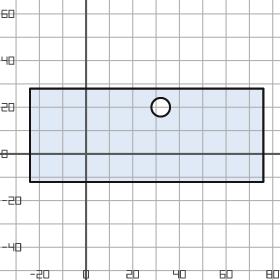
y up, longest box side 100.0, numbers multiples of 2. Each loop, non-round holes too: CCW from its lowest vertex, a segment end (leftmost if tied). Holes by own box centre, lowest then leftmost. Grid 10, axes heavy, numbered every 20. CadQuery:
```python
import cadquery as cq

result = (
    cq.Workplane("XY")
    .moveTo(-24.0, -12.0)
    .lineTo(76.0, -12.0)
    .lineTo(76.0, 28.0)
    .lineTo(-24.0, 28.0)
    .close()
    .moveTo(32.0, 20.0)
    .circle(4.0)
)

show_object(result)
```